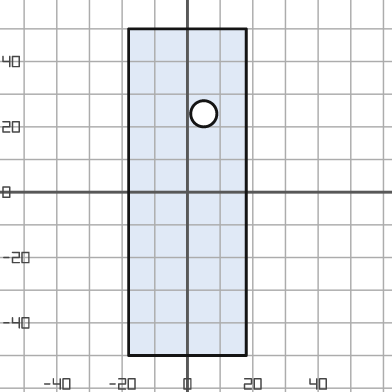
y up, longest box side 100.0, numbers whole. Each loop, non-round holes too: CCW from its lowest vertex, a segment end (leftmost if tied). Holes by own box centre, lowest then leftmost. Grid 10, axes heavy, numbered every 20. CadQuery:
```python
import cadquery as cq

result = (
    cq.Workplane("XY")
    .moveTo(-18.0, -50.0)
    .lineTo(18.0, -50.0)
    .lineTo(18.0, 50.0)
    .lineTo(-18.0, 50.0)
    .close()
    .moveTo(5.0, 24.0)
    .circle(4.0)
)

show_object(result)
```